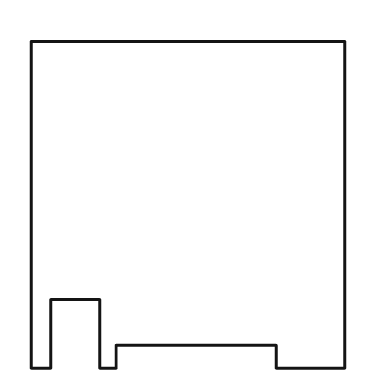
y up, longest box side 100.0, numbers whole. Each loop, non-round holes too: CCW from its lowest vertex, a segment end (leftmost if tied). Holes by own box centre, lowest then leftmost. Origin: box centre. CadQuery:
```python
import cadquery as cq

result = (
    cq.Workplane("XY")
    .moveTo(-48.0, -50.0)
    .lineTo(-42.0, -50.0)
    .lineTo(-42.0, -29.0)
    .lineTo(-27.0, -29.0)
    .lineTo(-27.0, -50.0)
    .lineTo(-22.0, -50.0)
    .lineTo(-22.0, -43.0)
    .lineTo(27.0, -43.0)
    .lineTo(27.0, -50.0)
    .lineTo(48.0, -50.0)
    .lineTo(48.0, 50.0)
    .lineTo(-48.0, 50.0)
    .close()
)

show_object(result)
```